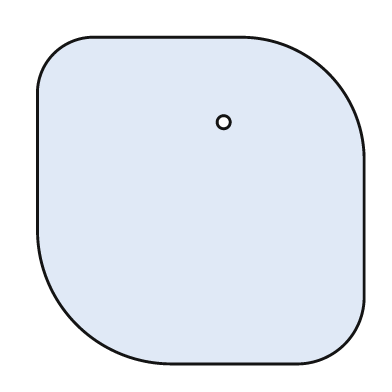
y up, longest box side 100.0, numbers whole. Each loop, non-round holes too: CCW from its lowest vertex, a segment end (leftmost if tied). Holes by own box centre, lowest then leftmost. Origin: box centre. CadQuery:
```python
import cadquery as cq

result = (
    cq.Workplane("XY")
    .moveTo(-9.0, -50.0)
    .lineTo(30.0, -50.0)
    .threePointArc((44.0, -44.0), (50.0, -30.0))
    .lineTo(50.0, 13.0)
    .threePointArc((39.0, 39.0), (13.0, 50.0))
    .lineTo(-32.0, 50.0)
    .threePointArc((-45.0, 45.0), (-50.0, 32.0))
    .lineTo(-50.0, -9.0)
    .threePointArc((-38.0, -38.0), (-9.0, -50.0))
    .close()
    .moveTo(7.0, 24.0)
    .circle(2.0)
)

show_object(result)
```